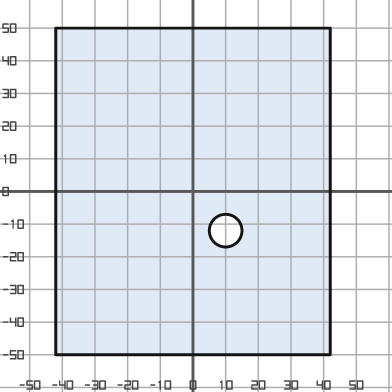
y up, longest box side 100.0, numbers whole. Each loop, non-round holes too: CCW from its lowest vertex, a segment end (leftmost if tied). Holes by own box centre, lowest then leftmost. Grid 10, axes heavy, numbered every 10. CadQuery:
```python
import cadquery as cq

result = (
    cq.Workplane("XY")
    .moveTo(-42.0, -50.0)
    .lineTo(42.0, -50.0)
    .lineTo(42.0, 50.0)
    .lineTo(-42.0, 50.0)
    .close()
    .moveTo(10.0, -12.0)
    .circle(5.0)
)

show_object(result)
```